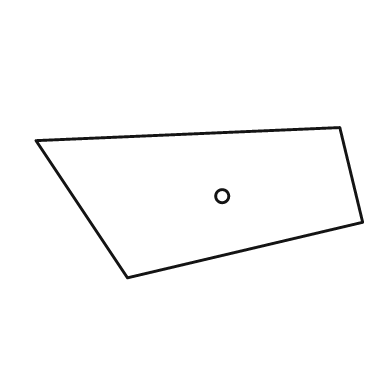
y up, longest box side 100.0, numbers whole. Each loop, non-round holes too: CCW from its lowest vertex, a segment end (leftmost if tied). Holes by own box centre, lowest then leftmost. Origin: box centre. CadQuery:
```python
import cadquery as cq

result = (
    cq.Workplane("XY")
    .moveTo(-22.0, -23.0)
    .lineTo(50.0, -6.0)
    .lineTo(43.0, 23.0)
    .lineTo(-50.0, 19.0)
    .close()
    .moveTo(7.0, 2.0)
    .circle(2.0)
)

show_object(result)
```